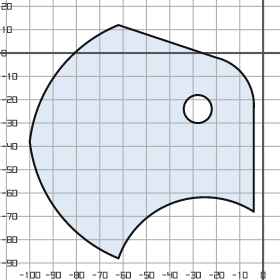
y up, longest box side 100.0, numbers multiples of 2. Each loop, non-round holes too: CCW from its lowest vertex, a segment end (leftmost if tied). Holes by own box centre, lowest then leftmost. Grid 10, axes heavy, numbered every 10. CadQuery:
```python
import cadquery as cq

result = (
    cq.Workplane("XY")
    .moveTo(-62.0, -88.0)
    .threePointArc((-38.0, -64.0), (-4.0, -68.0))
    .lineTo(-4.0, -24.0)
    .threePointArc((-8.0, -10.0), (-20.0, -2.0))
    .lineTo(-62.0, 12.0)
    .threePointArc((-88.0, -8.0), (-100.0, -38.0))
    .threePointArc((-88.0, -68.0), (-62.0, -88.0))
    .close()
    .moveTo(-28.0, -24.0)
    .circle(6.0)
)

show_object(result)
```